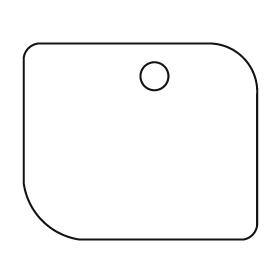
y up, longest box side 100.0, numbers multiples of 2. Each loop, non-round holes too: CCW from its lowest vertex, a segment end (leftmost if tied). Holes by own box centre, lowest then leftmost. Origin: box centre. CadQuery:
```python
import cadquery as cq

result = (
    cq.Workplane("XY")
    .moveTo(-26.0, -42.0)
    .lineTo(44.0, -42.0)
    .threePointArc((48.0, -40.0), (50.0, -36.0))
    .lineTo(50.0, 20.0)
    .threePointArc((44.0, 36.0), (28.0, 42.0))
    .lineTo(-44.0, 42.0)
    .threePointArc((-48.0, 40.0), (-50.0, 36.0))
    .lineTo(-50.0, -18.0)
    .threePointArc((-42.0, -34.0), (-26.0, -42.0))
    .close()
    .moveTo(6.0, 28.0)
    .circle(6.0)
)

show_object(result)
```